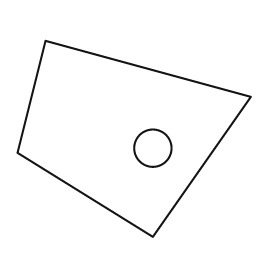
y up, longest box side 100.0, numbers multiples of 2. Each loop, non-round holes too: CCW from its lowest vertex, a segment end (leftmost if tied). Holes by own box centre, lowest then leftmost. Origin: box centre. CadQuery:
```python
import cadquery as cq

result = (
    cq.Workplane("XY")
    .moveTo(8.0, -42.0)
    .lineTo(50.0, 18.0)
    .lineTo(-38.0, 42.0)
    .lineTo(-50.0, -6.0)
    .close()
    .moveTo(8.0, -4.0)
    .circle(8.0)
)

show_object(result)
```